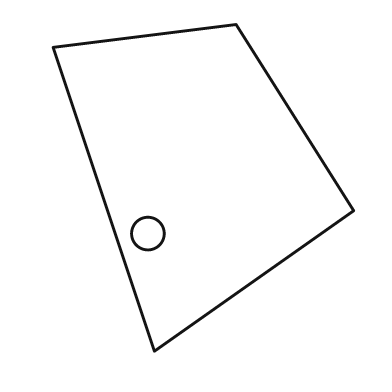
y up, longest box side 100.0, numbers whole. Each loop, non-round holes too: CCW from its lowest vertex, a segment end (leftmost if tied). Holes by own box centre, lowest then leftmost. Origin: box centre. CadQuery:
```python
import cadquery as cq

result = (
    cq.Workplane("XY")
    .moveTo(-15.0, -50.0)
    .lineTo(46.0, -7.0)
    .lineTo(10.0, 50.0)
    .lineTo(-46.0, 43.0)
    .close()
    .moveTo(-17.0, -14.0)
    .circle(5.0)
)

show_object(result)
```